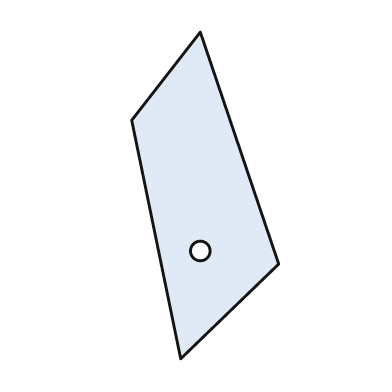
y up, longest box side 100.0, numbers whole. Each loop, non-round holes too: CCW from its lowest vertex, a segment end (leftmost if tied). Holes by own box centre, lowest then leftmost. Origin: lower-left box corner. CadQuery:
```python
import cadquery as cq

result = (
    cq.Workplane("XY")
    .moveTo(15.0, 0.0)
    .lineTo(45.0, 29.0)
    .lineTo(21.0, 100.0)
    .lineTo(0.0, 73.0)
    .close()
    .moveTo(21.0, 33.0)
    .circle(3.0)
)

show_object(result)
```